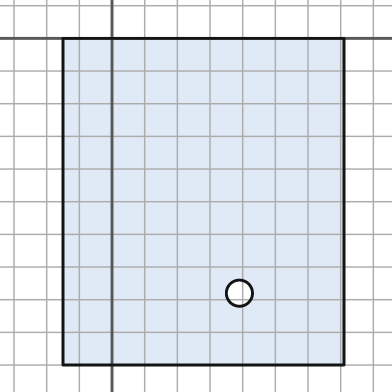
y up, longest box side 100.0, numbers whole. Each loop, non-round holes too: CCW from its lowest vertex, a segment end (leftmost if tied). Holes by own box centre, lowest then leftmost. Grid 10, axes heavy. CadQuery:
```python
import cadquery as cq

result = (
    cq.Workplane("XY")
    .moveTo(-15.0, -100.0)
    .lineTo(71.0, -100.0)
    .lineTo(71.0, 0.0)
    .lineTo(-15.0, 0.0)
    .close()
    .moveTo(39.0, -78.0)
    .circle(4.0)
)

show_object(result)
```